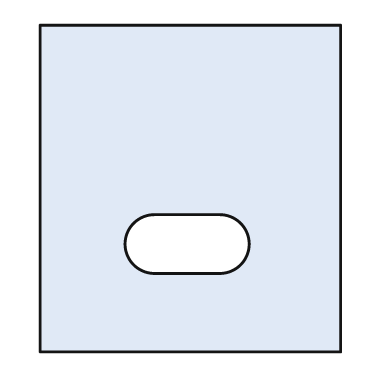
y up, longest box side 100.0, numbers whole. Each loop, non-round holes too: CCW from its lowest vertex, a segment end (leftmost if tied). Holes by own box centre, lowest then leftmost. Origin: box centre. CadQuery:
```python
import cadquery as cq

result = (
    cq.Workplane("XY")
    .moveTo(-46.0, -50.0)
    .lineTo(46.0, -50.0)
    .lineTo(46.0, 50.0)
    .lineTo(-46.0, 50.0)
    .close()
    .moveTo(-11.0, -26.0)
    .lineTo(9.0, -26.0)
    .threePointArc((18.0, -17.0), (9.0, -8.0))
    .lineTo(-11.0, -8.0)
    .threePointArc((-20.0, -17.0), (-11.0, -26.0))
    .close()
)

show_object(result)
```